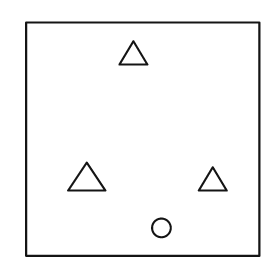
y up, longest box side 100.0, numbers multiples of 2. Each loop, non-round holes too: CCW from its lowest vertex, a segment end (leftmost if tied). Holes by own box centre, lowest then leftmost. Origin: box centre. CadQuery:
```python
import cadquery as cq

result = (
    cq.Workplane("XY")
    .moveTo(-50.0, -50.0)
    .lineTo(50.0, -50.0)
    .lineTo(50.0, 50.0)
    .lineTo(-50.0, 50.0)
    .close()
    .moveTo(8.0, -38.0)
    .circle(4.0)
    .moveTo(24.0, -22.0)
    .lineTo(36.0, -22.0)
    .lineTo(30.0, -12.0)
    .close()
    .moveTo(-32.0, -22.0)
    .lineTo(-16.0, -22.0)
    .lineTo(-24.0, -10.0)
    .close()
    .moveTo(-10.0, 32.0)
    .lineTo(2.0, 32.0)
    .lineTo(-4.0, 42.0)
    .close()
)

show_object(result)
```